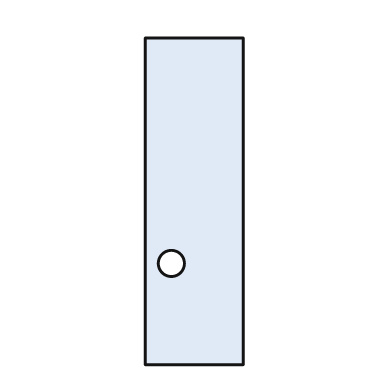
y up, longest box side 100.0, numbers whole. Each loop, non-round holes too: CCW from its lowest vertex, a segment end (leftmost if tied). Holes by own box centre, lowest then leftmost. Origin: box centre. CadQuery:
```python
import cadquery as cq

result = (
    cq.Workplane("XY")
    .moveTo(-15.0, -50.0)
    .lineTo(15.0, -50.0)
    .lineTo(15.0, 50.0)
    .lineTo(-15.0, 50.0)
    .close()
    .moveTo(-7.0, -19.0)
    .circle(4.0)
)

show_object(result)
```